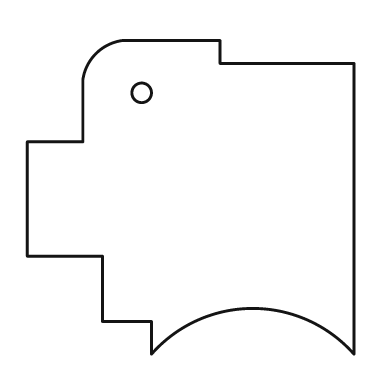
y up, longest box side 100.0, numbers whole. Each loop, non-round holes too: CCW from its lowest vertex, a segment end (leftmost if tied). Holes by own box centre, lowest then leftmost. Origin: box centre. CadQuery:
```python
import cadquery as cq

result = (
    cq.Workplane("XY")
    .moveTo(-12.0, -48.0)
    .threePointArc((19.0, -34.0), (50.0, -48.0))
    .lineTo(50.0, 41.0)
    .lineTo(9.0, 41.0)
    .lineTo(9.0, 48.0)
    .lineTo(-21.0, 48.0)
    .threePointArc((-29.0, 44.0), (-33.0, 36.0))
    .lineTo(-33.0, 17.0)
    .lineTo(-50.0, 17.0)
    .lineTo(-50.0, -18.0)
    .lineTo(-27.0, -18.0)
    .lineTo(-27.0, -38.0)
    .lineTo(-12.0, -38.0)
    .close()
    .moveTo(-15.0, 32.0)
    .circle(3.0)
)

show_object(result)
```